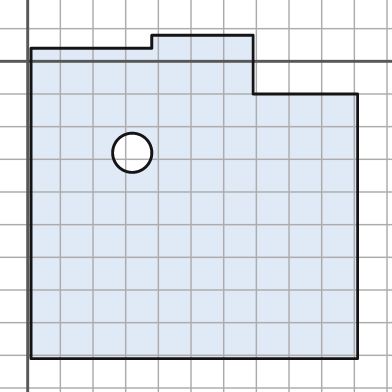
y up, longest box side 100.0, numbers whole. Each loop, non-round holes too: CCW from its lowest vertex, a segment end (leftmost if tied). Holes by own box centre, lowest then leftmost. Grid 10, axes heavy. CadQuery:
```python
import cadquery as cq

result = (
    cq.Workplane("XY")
    .moveTo(1.0, -91.0)
    .lineTo(101.0, -91.0)
    .lineTo(101.0, -10.0)
    .lineTo(69.0, -10.0)
    .lineTo(69.0, 8.0)
    .lineTo(38.0, 8.0)
    .lineTo(38.0, 4.0)
    .lineTo(1.0, 4.0)
    .close()
    .moveTo(32.0, -28.0)
    .circle(6.0)
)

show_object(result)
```